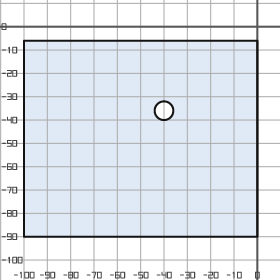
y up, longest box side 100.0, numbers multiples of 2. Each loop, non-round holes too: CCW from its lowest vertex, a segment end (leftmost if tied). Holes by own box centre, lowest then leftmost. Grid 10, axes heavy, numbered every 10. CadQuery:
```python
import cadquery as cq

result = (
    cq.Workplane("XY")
    .moveTo(-100.0, -90.0)
    .lineTo(0.0, -90.0)
    .lineTo(0.0, -6.0)
    .lineTo(-100.0, -6.0)
    .close()
    .moveTo(-40.0, -36.0)
    .circle(4.0)
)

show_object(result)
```